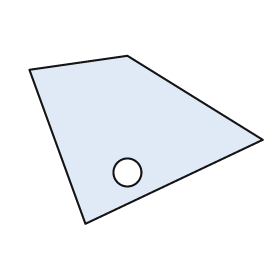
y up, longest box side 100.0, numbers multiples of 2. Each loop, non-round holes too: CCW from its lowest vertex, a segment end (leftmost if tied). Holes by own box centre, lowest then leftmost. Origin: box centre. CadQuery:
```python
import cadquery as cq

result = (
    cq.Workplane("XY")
    .moveTo(-26.0, -36.0)
    .lineTo(50.0, 0.0)
    .lineTo(-8.0, 36.0)
    .lineTo(-50.0, 30.0)
    .close()
    .moveTo(-8.0, -14.0)
    .circle(6.0)
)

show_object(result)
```